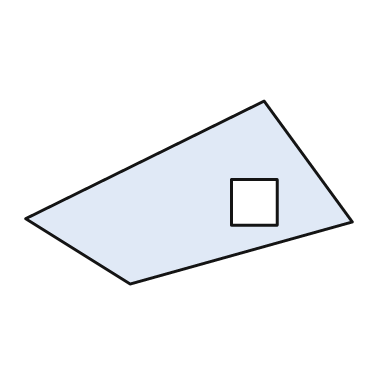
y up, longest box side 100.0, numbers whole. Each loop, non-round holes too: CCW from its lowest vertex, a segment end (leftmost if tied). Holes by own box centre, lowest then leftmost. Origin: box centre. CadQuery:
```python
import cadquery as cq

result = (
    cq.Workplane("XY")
    .moveTo(-18.0, -28.0)
    .lineTo(50.0, -9.0)
    .lineTo(23.0, 28.0)
    .lineTo(-50.0, -8.0)
    .close()
    .moveTo(13.0, -10.0)
    .lineTo(27.0, -10.0)
    .lineTo(27.0, 4.0)
    .lineTo(13.0, 4.0)
    .close()
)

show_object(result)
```